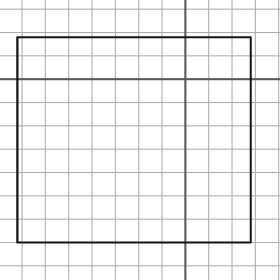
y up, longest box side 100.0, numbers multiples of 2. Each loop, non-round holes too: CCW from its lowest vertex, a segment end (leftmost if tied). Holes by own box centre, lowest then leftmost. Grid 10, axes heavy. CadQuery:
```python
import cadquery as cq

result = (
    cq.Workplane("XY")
    .moveTo(-72.0, -70.0)
    .lineTo(28.0, -70.0)
    .lineTo(28.0, 18.0)
    .lineTo(-72.0, 18.0)
    .close()
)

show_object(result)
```